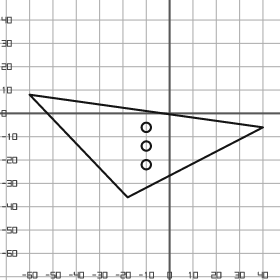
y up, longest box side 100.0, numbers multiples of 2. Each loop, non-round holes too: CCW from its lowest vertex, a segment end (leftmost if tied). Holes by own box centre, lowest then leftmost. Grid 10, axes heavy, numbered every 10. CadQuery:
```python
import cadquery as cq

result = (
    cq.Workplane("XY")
    .moveTo(-18.0, -36.0)
    .lineTo(40.0, -6.0)
    .lineTo(-60.0, 8.0)
    .close()
    .moveTo(-10.0, -22.0)
    .circle(2.0)
    .moveTo(-10.0, -14.0)
    .circle(2.0)
    .moveTo(-10.0, -6.0)
    .circle(2.0)
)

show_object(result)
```